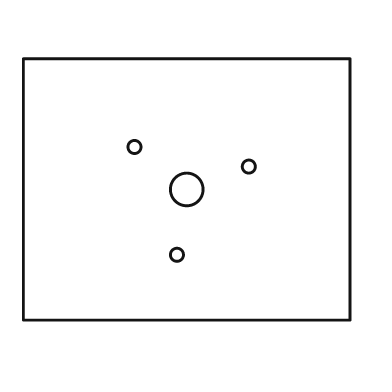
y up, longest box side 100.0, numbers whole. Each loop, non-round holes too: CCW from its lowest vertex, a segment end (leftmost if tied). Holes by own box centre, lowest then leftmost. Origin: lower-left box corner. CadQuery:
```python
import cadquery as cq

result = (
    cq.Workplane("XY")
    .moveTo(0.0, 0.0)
    .lineTo(100.0, 0.0)
    .lineTo(100.0, 80.0)
    .lineTo(0.0, 80.0)
    .close()
    .moveTo(47.0, 20.0)
    .circle(2.0)
    .moveTo(50.0, 40.0)
    .circle(5.0)
    .moveTo(69.0, 47.0)
    .circle(2.0)
    .moveTo(34.0, 53.0)
    .circle(2.0)
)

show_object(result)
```